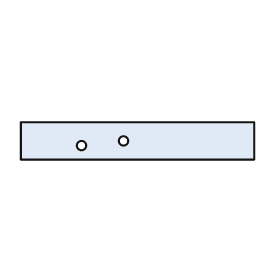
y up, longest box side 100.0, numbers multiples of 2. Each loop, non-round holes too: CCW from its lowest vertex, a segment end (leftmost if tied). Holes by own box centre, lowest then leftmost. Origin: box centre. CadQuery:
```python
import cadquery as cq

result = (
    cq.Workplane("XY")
    .moveTo(-50.0, -8.0)
    .lineTo(50.0, -8.0)
    .lineTo(50.0, 8.0)
    .lineTo(-50.0, 8.0)
    .close()
    .moveTo(-24.0, -2.0)
    .circle(2.0)
    .moveTo(-6.0, 0.0)
    .circle(2.0)
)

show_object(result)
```